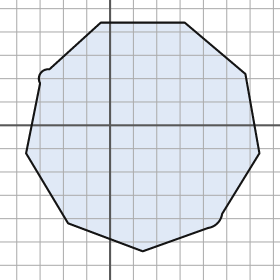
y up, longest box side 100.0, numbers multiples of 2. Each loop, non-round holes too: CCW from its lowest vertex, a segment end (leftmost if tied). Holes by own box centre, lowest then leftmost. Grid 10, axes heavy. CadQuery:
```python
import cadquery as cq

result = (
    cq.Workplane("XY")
    .moveTo(14.0, -54.0)
    .lineTo(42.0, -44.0)
    .threePointArc((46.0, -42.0), (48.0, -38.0))
    .lineTo(64.0, -12.0)
    .lineTo(58.0, 22.0)
    .lineTo(32.0, 44.0)
    .lineTo(-4.0, 44.0)
    .lineTo(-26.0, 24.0)
    .threePointArc((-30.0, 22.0), (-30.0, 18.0))
    .lineTo(-36.0, -12.0)
    .lineTo(-18.0, -42.0)
    .close()
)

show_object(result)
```